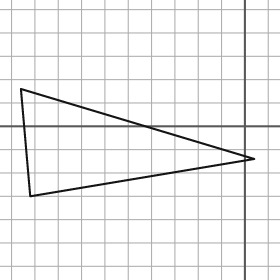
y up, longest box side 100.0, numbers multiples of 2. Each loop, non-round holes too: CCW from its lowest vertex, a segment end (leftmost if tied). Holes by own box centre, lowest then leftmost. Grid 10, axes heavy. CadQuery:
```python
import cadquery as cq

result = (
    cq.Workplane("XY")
    .moveTo(-92.0, -30.0)
    .lineTo(4.0, -14.0)
    .lineTo(-96.0, 16.0)
    .close()
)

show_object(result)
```